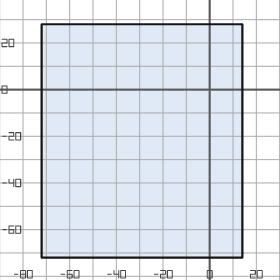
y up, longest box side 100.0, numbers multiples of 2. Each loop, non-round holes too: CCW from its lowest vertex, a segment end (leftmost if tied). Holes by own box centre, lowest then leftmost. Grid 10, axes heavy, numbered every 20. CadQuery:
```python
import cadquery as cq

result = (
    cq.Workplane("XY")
    .moveTo(-72.0, -72.0)
    .lineTo(14.0, -72.0)
    .lineTo(14.0, 28.0)
    .lineTo(-72.0, 28.0)
    .close()
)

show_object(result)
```